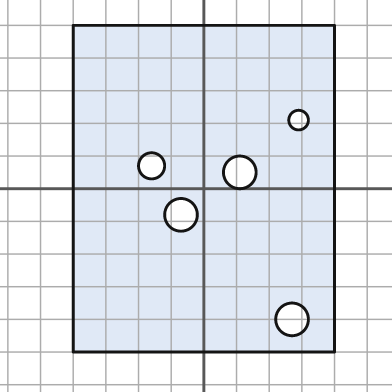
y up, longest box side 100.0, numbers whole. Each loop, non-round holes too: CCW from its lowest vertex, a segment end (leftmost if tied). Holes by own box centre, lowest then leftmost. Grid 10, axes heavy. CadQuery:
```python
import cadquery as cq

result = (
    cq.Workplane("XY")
    .moveTo(-40.0, -50.0)
    .lineTo(40.0, -50.0)
    .lineTo(40.0, 50.0)
    .lineTo(-40.0, 50.0)
    .close()
    .moveTo(27.0, -40.0)
    .circle(5.0)
    .moveTo(-7.0, -8.0)
    .circle(5.0)
    .moveTo(11.0, 5.0)
    .circle(5.0)
    .moveTo(-16.0, 7.0)
    .circle(4.0)
    .moveTo(29.0, 21.0)
    .circle(3.0)
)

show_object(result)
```